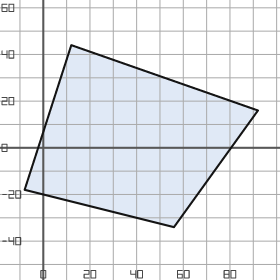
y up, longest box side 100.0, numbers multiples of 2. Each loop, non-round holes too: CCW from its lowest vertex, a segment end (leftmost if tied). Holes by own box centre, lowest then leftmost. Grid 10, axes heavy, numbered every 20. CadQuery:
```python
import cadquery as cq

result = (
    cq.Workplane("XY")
    .moveTo(56.0, -34.0)
    .lineTo(92.0, 16.0)
    .lineTo(12.0, 44.0)
    .lineTo(-8.0, -18.0)
    .close()
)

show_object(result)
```